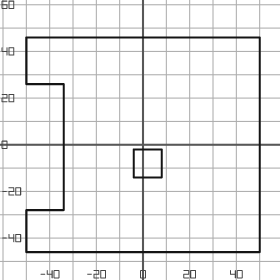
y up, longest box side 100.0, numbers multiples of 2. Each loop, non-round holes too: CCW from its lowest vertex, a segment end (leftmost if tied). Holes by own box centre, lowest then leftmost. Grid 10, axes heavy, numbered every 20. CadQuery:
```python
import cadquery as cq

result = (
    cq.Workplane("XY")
    .moveTo(-50.0, -46.0)
    .lineTo(50.0, -46.0)
    .lineTo(50.0, 46.0)
    .lineTo(-50.0, 46.0)
    .lineTo(-50.0, 26.0)
    .lineTo(-34.0, 26.0)
    .lineTo(-34.0, -28.0)
    .lineTo(-50.0, -28.0)
    .close()
    .moveTo(-4.0, -14.0)
    .lineTo(8.0, -14.0)
    .lineTo(8.0, -2.0)
    .lineTo(-4.0, -2.0)
    .close()
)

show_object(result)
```